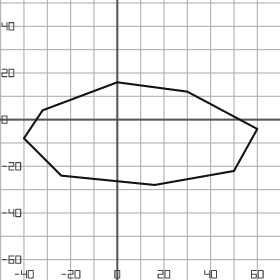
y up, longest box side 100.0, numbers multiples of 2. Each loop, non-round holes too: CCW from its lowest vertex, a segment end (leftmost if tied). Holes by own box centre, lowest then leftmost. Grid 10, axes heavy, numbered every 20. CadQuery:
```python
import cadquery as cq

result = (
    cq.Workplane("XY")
    .moveTo(16.0, -28.0)
    .lineTo(50.0, -22.0)
    .lineTo(60.0, -4.0)
    .lineTo(30.0, 12.0)
    .lineTo(0.0, 16.0)
    .lineTo(-32.0, 4.0)
    .lineTo(-40.0, -8.0)
    .lineTo(-24.0, -24.0)
    .close()
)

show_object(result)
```